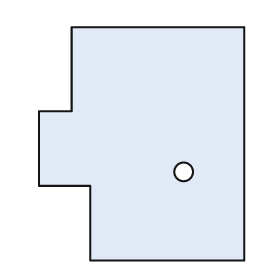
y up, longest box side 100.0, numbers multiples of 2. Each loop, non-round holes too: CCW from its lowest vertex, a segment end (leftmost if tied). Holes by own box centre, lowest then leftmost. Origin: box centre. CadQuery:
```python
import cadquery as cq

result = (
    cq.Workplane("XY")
    .moveTo(-22.0, -50.0)
    .lineTo(44.0, -50.0)
    .lineTo(44.0, 50.0)
    .lineTo(-30.0, 50.0)
    .lineTo(-30.0, 14.0)
    .lineTo(-44.0, 14.0)
    .lineTo(-44.0, -18.0)
    .lineTo(-22.0, -18.0)
    .close()
    .moveTo(18.0, -12.0)
    .circle(4.0)
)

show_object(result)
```